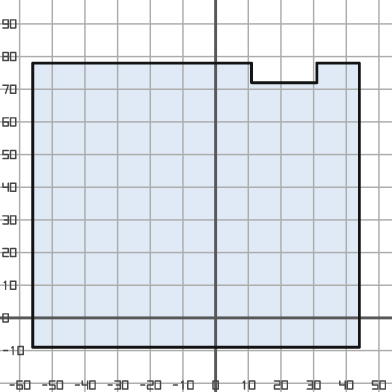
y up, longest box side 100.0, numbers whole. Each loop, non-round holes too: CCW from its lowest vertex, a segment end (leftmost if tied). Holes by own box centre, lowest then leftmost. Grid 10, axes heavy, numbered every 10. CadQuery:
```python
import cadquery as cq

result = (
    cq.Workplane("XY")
    .moveTo(-56.0, -9.0)
    .lineTo(44.0, -9.0)
    .lineTo(44.0, 78.0)
    .lineTo(31.0, 78.0)
    .lineTo(31.0, 72.0)
    .lineTo(11.0, 72.0)
    .lineTo(11.0, 78.0)
    .lineTo(-56.0, 78.0)
    .close()
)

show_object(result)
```